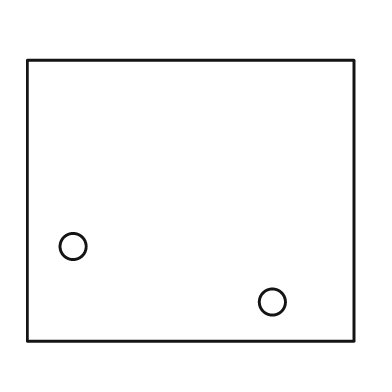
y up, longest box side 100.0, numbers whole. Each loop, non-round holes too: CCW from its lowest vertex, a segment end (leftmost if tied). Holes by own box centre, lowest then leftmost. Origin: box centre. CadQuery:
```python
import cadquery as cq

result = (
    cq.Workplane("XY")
    .moveTo(-50.0, -43.0)
    .lineTo(50.0, -43.0)
    .lineTo(50.0, 43.0)
    .lineTo(-50.0, 43.0)
    .close()
    .moveTo(25.0, -31.0)
    .circle(4.0)
    .moveTo(-36.0, -14.0)
    .circle(4.0)
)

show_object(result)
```